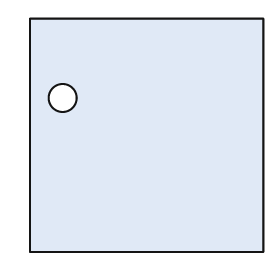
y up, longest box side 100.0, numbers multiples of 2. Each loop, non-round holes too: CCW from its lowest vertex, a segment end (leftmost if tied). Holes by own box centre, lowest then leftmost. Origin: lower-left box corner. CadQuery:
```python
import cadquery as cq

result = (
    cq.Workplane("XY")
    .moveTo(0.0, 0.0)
    .lineTo(100.0, 0.0)
    .lineTo(100.0, 100.0)
    .lineTo(0.0, 100.0)
    .close()
    .moveTo(14.0, 66.0)
    .circle(6.0)
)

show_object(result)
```